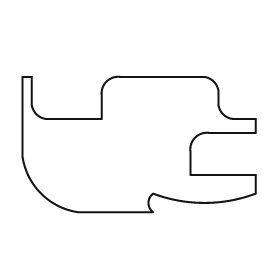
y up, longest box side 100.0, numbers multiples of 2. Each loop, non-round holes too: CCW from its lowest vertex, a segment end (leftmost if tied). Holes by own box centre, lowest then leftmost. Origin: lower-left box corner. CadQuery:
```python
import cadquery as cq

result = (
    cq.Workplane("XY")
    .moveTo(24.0, 0.0)
    .lineTo(56.0, 0.0)
    .threePointArc((54.0, 4.0), (56.0, 8.0))
    .threePointArc((78.0, 4.0), (100.0, 8.0))
    .lineTo(100.0, 16.0)
    .lineTo(72.0, 16.0)
    .lineTo(72.0, 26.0)
    .threePointArc((74.0, 32.0), (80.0, 34.0))
    .lineTo(100.0, 34.0)
    .lineTo(100.0, 40.0)
    .lineTo(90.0, 40.0)
    .threePointArc((86.0, 42.0), (84.0, 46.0))
    .lineTo(84.0, 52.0)
    .threePointArc((82.0, 56.0), (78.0, 58.0))
    .lineTo(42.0, 58.0)
    .threePointArc((36.0, 56.0), (34.0, 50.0))
    .lineTo(34.0, 40.0)
    .lineTo(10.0, 40.0)
    .threePointArc((6.0, 42.0), (4.0, 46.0))
    .lineTo(4.0, 58.0)
    .lineTo(0.0, 58.0)
    .lineTo(0.0, 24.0)
    .threePointArc((8.0, 8.0), (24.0, 0.0))
    .close()
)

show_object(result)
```